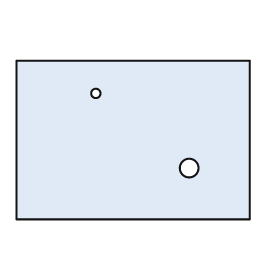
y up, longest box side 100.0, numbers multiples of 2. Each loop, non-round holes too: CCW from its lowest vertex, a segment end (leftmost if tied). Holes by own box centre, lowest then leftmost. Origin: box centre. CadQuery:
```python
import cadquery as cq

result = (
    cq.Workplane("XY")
    .moveTo(-50.0, -34.0)
    .lineTo(50.0, -34.0)
    .lineTo(50.0, 34.0)
    .lineTo(-50.0, 34.0)
    .close()
    .moveTo(24.0, -12.0)
    .circle(4.0)
    .moveTo(-16.0, 20.0)
    .circle(2.0)
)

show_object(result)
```